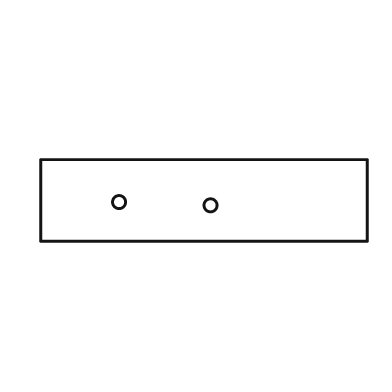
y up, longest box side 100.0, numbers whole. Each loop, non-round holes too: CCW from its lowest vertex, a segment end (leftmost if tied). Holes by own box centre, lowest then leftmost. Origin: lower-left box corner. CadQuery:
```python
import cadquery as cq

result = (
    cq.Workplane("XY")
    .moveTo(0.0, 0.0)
    .lineTo(100.0, 0.0)
    .lineTo(100.0, 25.0)
    .lineTo(0.0, 25.0)
    .close()
    .moveTo(52.0, 11.0)
    .circle(2.0)
    .moveTo(24.0, 12.0)
    .circle(2.0)
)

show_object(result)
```